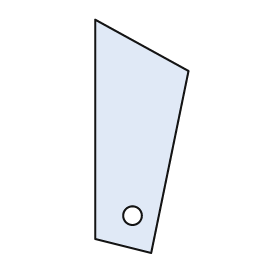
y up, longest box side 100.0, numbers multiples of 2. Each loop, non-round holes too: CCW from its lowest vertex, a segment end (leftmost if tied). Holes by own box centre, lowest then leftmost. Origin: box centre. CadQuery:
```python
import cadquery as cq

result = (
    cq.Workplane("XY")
    .moveTo(4.0, -50.0)
    .lineTo(20.0, 28.0)
    .lineTo(-20.0, 50.0)
    .lineTo(-20.0, -44.0)
    .close()
    .moveTo(-4.0, -34.0)
    .circle(4.0)
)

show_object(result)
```